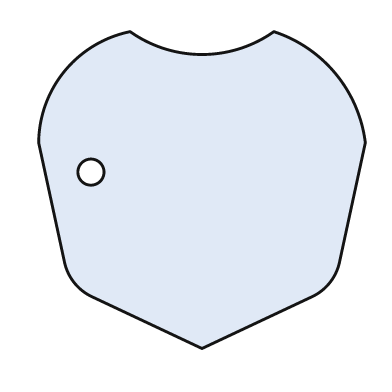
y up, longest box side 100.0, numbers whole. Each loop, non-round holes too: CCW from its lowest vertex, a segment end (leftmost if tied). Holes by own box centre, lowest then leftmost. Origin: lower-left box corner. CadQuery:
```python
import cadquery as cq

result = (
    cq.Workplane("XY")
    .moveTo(50.0, 0.0)
    .lineTo(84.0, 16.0)
    .threePointArc((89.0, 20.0), (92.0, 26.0))
    .lineTo(100.0, 63.0)
    .threePointArc((91.0, 84.0), (72.0, 97.0))
    .threePointArc((50.0, 90.0), (28.0, 97.0))
    .threePointArc((8.0, 85.0), (0.0, 63.0))
    .lineTo(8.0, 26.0)
    .threePointArc((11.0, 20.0), (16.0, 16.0))
    .close()
    .moveTo(16.0, 54.0)
    .circle(4.0)
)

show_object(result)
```